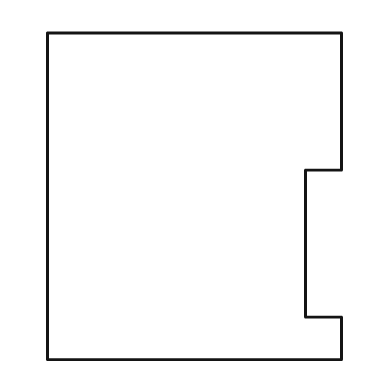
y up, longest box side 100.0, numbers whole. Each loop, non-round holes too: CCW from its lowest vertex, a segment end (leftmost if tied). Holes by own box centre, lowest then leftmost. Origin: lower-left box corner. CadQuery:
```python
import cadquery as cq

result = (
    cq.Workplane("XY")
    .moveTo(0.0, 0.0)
    .lineTo(90.0, 0.0)
    .lineTo(90.0, 13.0)
    .lineTo(79.0, 13.0)
    .lineTo(79.0, 58.0)
    .lineTo(90.0, 58.0)
    .lineTo(90.0, 100.0)
    .lineTo(0.0, 100.0)
    .close()
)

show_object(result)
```